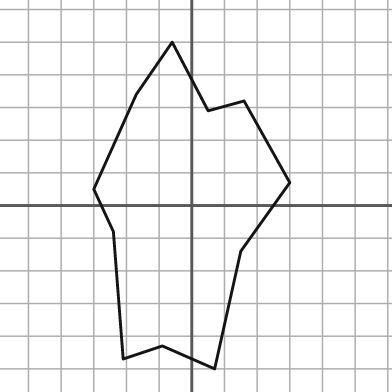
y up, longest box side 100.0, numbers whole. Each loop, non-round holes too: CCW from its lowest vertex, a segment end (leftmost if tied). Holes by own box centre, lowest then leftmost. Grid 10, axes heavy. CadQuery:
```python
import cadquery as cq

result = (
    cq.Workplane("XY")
    .moveTo(7.0, -50.0)
    .lineTo(15.0, -14.0)
    .lineTo(30.0, 7.0)
    .lineTo(16.0, 32.0)
    .lineTo(5.0, 29.0)
    .lineTo(-6.0, 50.0)
    .lineTo(-17.0, 34.0)
    .lineTo(-30.0, 5.0)
    .lineTo(-24.0, -8.0)
    .lineTo(-21.0, -47.0)
    .lineTo(-9.0, -43.0)
    .close()
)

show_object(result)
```